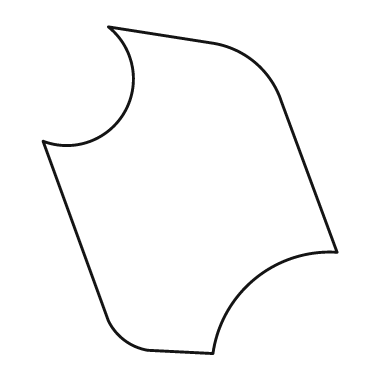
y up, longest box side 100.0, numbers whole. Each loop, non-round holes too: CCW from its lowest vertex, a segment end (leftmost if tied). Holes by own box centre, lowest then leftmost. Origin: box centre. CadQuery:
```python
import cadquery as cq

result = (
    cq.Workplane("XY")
    .moveTo(7.0, -50.0)
    .threePointArc((20.0, -27.0), (45.0, -19.0))
    .lineTo(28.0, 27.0)
    .threePointArc((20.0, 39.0), (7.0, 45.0))
    .lineTo(-25.0, 50.0)
    .threePointArc((-20.0, 24.0), (-45.0, 15.0))
    .lineTo(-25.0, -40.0)
    .threePointArc((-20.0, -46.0), (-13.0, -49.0))
    .close()
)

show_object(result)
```